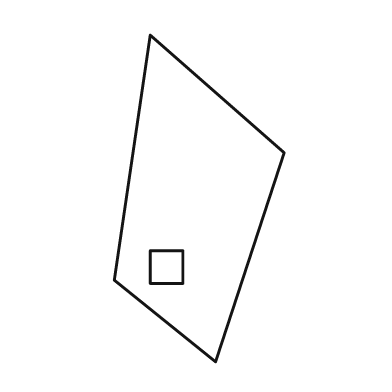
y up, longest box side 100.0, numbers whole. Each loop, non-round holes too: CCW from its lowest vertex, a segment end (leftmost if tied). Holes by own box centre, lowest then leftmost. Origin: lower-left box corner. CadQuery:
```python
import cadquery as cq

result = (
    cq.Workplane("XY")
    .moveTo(31.0, 0.0)
    .lineTo(52.0, 64.0)
    .lineTo(11.0, 100.0)
    .lineTo(0.0, 25.0)
    .close()
    .moveTo(11.0, 24.0)
    .lineTo(21.0, 24.0)
    .lineTo(21.0, 34.0)
    .lineTo(11.0, 34.0)
    .close()
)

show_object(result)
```